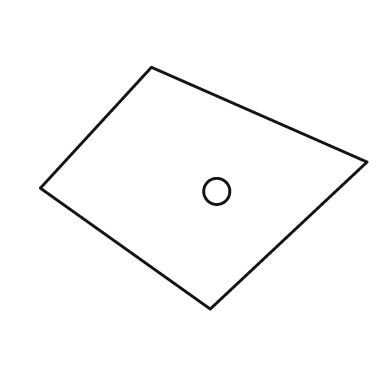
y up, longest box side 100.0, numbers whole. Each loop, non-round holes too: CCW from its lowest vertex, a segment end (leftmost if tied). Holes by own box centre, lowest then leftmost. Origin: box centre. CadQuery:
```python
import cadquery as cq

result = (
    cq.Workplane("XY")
    .moveTo(2.0, -37.0)
    .lineTo(50.0, 8.0)
    .lineTo(-16.0, 37.0)
    .lineTo(-50.0, 0.0)
    .close()
    .moveTo(4.0, -1.0)
    .circle(4.0)
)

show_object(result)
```